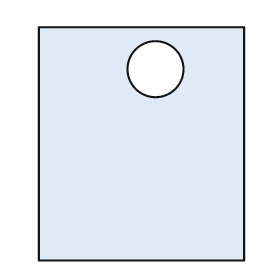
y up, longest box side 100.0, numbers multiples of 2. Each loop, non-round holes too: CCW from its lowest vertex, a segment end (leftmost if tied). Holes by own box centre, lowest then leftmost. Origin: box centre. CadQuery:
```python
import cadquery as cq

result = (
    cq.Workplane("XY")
    .moveTo(-44.0, -50.0)
    .lineTo(44.0, -50.0)
    .lineTo(44.0, 50.0)
    .lineTo(-44.0, 50.0)
    .close()
    .moveTo(6.0, 32.0)
    .circle(12.0)
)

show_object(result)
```